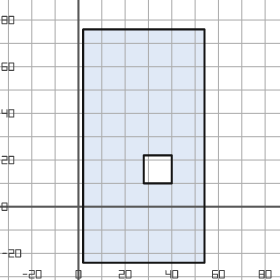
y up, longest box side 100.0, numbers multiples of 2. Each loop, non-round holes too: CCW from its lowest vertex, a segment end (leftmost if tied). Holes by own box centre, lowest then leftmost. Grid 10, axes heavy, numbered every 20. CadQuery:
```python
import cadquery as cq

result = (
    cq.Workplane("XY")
    .moveTo(2.0, -24.0)
    .lineTo(54.0, -24.0)
    .lineTo(54.0, 76.0)
    .lineTo(2.0, 76.0)
    .close()
    .moveTo(28.0, 10.0)
    .lineTo(40.0, 10.0)
    .lineTo(40.0, 22.0)
    .lineTo(28.0, 22.0)
    .close()
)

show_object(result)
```